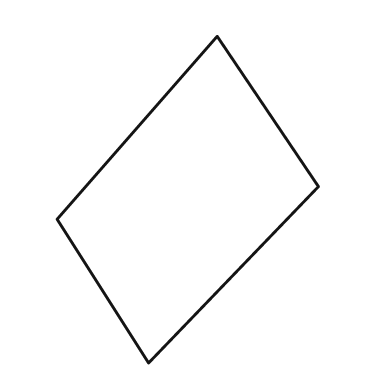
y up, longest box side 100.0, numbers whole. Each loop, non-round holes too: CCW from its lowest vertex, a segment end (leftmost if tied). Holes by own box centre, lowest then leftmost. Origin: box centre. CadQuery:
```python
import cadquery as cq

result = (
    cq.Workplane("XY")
    .moveTo(-12.0, -50.0)
    .lineTo(40.0, 4.0)
    .lineTo(9.0, 50.0)
    .lineTo(-40.0, -6.0)
    .close()
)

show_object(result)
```